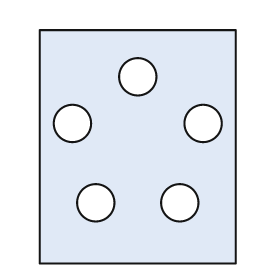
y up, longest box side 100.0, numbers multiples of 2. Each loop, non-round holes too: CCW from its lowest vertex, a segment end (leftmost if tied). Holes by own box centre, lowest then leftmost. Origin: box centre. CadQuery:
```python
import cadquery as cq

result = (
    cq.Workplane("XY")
    .moveTo(-42.0, -50.0)
    .lineTo(42.0, -50.0)
    .lineTo(42.0, 50.0)
    .lineTo(-42.0, 50.0)
    .close()
    .moveTo(-18.0, -24.0)
    .circle(8.0)
    .moveTo(18.0, -24.0)
    .circle(8.0)
    .moveTo(-28.0, 10.0)
    .circle(8.0)
    .moveTo(28.0, 10.0)
    .circle(8.0)
    .moveTo(0.0, 30.0)
    .circle(8.0)
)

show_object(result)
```